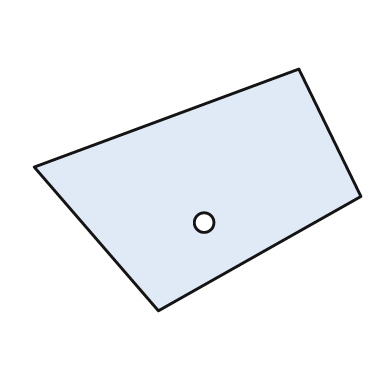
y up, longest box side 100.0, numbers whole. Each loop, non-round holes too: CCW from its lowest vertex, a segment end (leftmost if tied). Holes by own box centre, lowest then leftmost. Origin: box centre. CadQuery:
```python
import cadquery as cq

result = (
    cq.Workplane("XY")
    .moveTo(-12.0, -37.0)
    .lineTo(50.0, -2.0)
    .lineTo(31.0, 37.0)
    .lineTo(-50.0, 7.0)
    .close()
    .moveTo(2.0, -10.0)
    .circle(3.0)
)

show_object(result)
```